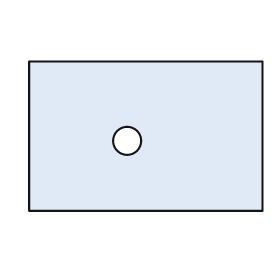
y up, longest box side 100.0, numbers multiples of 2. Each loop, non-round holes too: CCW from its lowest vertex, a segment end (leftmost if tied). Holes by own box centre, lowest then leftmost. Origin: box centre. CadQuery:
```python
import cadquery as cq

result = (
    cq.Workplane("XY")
    .moveTo(-50.0, -32.0)
    .lineTo(50.0, -32.0)
    .lineTo(50.0, 32.0)
    .lineTo(-50.0, 32.0)
    .close()
    .moveTo(-8.0, -2.0)
    .circle(6.0)
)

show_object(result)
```